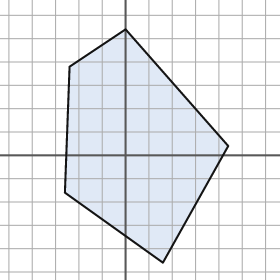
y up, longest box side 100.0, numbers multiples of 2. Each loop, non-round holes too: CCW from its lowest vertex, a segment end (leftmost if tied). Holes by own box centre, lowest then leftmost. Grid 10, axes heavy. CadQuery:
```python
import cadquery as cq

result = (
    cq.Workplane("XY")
    .moveTo(16.0, -46.0)
    .lineTo(44.0, 4.0)
    .lineTo(0.0, 54.0)
    .lineTo(-24.0, 38.0)
    .lineTo(-26.0, -16.0)
    .close()
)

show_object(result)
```